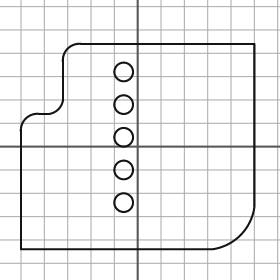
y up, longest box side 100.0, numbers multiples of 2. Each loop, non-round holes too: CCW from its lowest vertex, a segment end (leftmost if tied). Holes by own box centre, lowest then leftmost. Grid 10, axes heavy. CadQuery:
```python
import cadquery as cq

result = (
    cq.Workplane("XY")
    .moveTo(-50.0, -44.0)
    .lineTo(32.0, -44.0)
    .threePointArc((44.0, -38.0), (50.0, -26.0))
    .lineTo(50.0, 44.0)
    .lineTo(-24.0, 44.0)
    .threePointArc((-30.0, 42.0), (-32.0, 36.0))
    .lineTo(-32.0, 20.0)
    .threePointArc((-34.0, 16.0), (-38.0, 14.0))
    .lineTo(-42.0, 14.0)
    .threePointArc((-48.0, 12.0), (-50.0, 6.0))
    .close()
    .moveTo(-6.0, -24.0)
    .circle(4.0)
    .moveTo(-6.0, -10.0)
    .circle(4.0)
    .moveTo(-6.0, 4.0)
    .circle(4.0)
    .moveTo(-6.0, 18.0)
    .circle(4.0)
    .moveTo(-6.0, 32.0)
    .circle(4.0)
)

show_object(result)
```